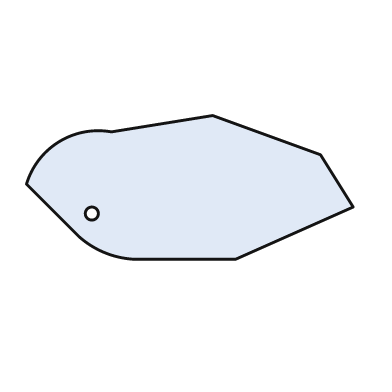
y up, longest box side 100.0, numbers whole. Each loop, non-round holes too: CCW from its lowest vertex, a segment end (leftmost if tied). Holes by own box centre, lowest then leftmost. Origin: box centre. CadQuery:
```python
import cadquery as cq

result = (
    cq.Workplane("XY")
    .moveTo(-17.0, -22.0)
    .lineTo(14.0, -22.0)
    .lineTo(50.0, -6.0)
    .lineTo(40.0, 10.0)
    .lineTo(7.0, 22.0)
    .lineTo(-24.0, 17.0)
    .threePointArc((-40.0, 14.0), (-50.0, 1.0))
    .lineTo(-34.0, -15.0)
    .threePointArc((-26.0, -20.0), (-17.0, -22.0))
    .close()
    .moveTo(-30.0, -8.0)
    .circle(2.0)
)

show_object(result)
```